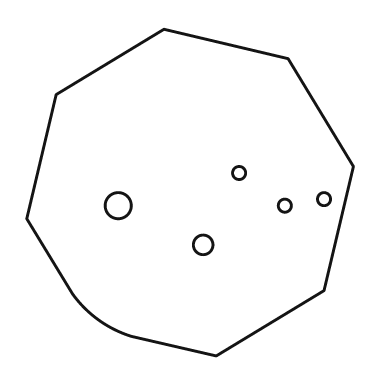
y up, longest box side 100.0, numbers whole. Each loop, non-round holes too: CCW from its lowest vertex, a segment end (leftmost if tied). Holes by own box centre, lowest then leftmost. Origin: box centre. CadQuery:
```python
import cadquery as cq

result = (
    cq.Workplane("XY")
    .moveTo(8.0, -50.0)
    .lineTo(41.0, -30.0)
    .lineTo(50.0, 8.0)
    .lineTo(30.0, 41.0)
    .lineTo(-8.0, 50.0)
    .lineTo(-41.0, 30.0)
    .lineTo(-50.0, -8.0)
    .lineTo(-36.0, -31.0)
    .threePointArc((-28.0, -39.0), (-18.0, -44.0))
    .close()
    .moveTo(4.0, -16.0)
    .circle(3.0)
    .moveTo(-22.0, -4.0)
    .circle(4.0)
    .moveTo(29.0, -4.0)
    .circle(2.0)
    .moveTo(41.0, -2.0)
    .circle(2.0)
    .moveTo(15.0, 6.0)
    .circle(2.0)
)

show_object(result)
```